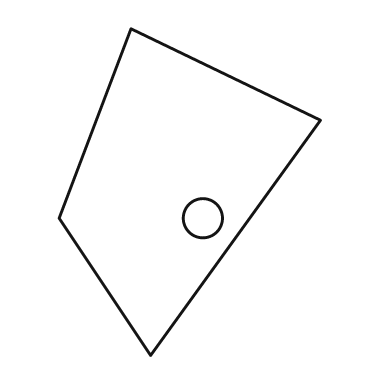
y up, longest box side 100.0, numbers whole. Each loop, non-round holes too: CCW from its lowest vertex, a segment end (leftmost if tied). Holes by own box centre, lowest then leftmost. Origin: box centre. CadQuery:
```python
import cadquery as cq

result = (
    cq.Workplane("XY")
    .moveTo(-12.0, -50.0)
    .lineTo(40.0, 22.0)
    .lineTo(-18.0, 50.0)
    .lineTo(-40.0, -8.0)
    .close()
    .moveTo(4.0, -8.0)
    .circle(6.0)
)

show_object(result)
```